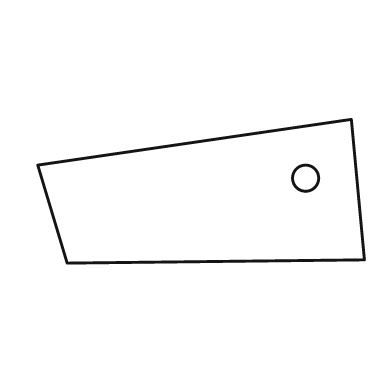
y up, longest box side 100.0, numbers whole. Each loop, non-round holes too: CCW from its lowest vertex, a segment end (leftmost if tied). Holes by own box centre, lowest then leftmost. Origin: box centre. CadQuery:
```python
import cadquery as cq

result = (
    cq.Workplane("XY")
    .moveTo(-41.0, -22.0)
    .lineTo(50.0, -21.0)
    .lineTo(46.0, 22.0)
    .lineTo(-50.0, 8.0)
    .close()
    .moveTo(32.0, 4.0)
    .circle(4.0)
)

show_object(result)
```